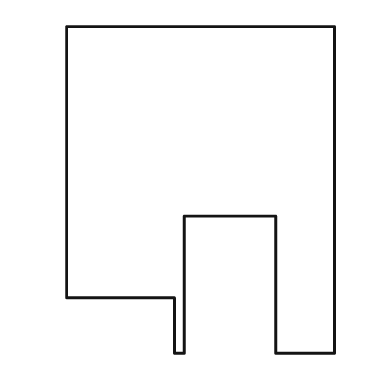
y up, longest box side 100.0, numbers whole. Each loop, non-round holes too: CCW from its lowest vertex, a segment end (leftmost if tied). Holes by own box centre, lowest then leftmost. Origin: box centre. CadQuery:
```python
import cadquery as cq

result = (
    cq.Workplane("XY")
    .moveTo(-8.0, -50.0)
    .lineTo(-5.0, -50.0)
    .lineTo(-5.0, -8.0)
    .lineTo(23.0, -8.0)
    .lineTo(23.0, -50.0)
    .lineTo(41.0, -50.0)
    .lineTo(41.0, 50.0)
    .lineTo(-41.0, 50.0)
    .lineTo(-41.0, -33.0)
    .lineTo(-8.0, -33.0)
    .close()
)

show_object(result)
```